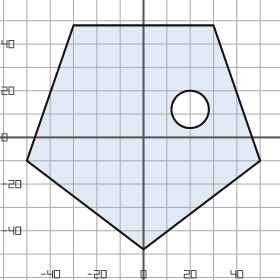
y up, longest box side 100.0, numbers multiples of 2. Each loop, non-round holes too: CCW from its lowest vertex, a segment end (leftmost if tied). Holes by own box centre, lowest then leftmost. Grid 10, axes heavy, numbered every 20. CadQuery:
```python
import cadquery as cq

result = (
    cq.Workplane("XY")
    .moveTo(0.0, -48.0)
    .lineTo(50.0, -10.0)
    .lineTo(30.0, 48.0)
    .lineTo(-30.0, 48.0)
    .lineTo(-50.0, -10.0)
    .close()
    .moveTo(20.0, 12.0)
    .circle(8.0)
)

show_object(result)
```